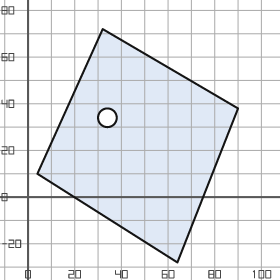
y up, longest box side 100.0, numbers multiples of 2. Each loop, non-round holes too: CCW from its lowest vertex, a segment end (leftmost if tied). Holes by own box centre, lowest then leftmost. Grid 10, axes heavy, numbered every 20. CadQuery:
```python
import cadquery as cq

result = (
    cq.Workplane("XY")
    .moveTo(64.0, -28.0)
    .lineTo(90.0, 38.0)
    .lineTo(32.0, 72.0)
    .lineTo(4.0, 10.0)
    .close()
    .moveTo(34.0, 34.0)
    .circle(4.0)
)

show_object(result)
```